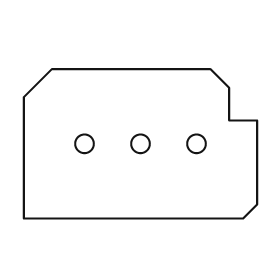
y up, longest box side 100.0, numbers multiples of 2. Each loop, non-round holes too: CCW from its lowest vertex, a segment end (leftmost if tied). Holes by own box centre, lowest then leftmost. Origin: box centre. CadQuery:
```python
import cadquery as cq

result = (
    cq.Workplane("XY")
    .moveTo(-50.0, -32.0)
    .lineTo(44.0, -32.0)
    .lineTo(50.0, -26.0)
    .lineTo(50.0, 10.0)
    .lineTo(38.0, 10.0)
    .lineTo(38.0, 24.0)
    .lineTo(30.0, 32.0)
    .lineTo(-38.0, 32.0)
    .lineTo(-50.0, 20.0)
    .close()
    .moveTo(-24.0, 0.0)
    .circle(4.0)
    .moveTo(0.0, 0.0)
    .circle(4.0)
    .moveTo(24.0, 0.0)
    .circle(4.0)
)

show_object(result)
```